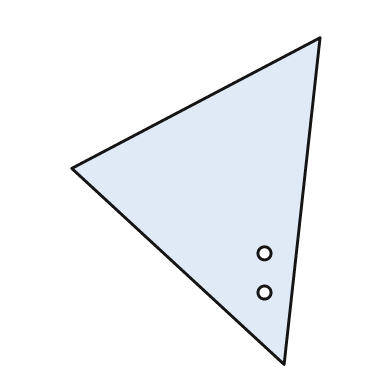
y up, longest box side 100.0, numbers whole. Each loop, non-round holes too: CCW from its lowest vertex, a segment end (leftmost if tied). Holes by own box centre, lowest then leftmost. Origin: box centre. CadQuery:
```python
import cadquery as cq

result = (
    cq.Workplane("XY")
    .moveTo(27.0, -50.0)
    .lineTo(38.0, 50.0)
    .lineTo(-38.0, 10.0)
    .close()
    .moveTo(21.0, -28.0)
    .circle(2.0)
    .moveTo(21.0, -16.0)
    .circle(2.0)
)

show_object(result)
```